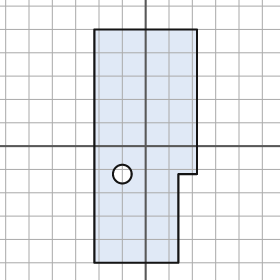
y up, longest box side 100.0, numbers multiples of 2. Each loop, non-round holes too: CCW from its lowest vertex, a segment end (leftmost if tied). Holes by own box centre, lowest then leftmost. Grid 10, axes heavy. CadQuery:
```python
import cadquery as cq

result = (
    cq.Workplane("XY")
    .moveTo(-22.0, -50.0)
    .lineTo(14.0, -50.0)
    .lineTo(14.0, -12.0)
    .lineTo(22.0, -12.0)
    .lineTo(22.0, 50.0)
    .lineTo(-22.0, 50.0)
    .close()
    .moveTo(-10.0, -12.0)
    .circle(4.0)
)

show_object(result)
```